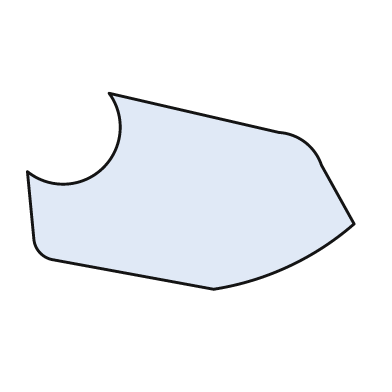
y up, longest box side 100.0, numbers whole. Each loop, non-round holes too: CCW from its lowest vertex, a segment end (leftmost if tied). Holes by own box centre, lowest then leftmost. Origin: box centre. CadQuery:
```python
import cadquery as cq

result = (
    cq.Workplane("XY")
    .moveTo(7.0, -30.0)
    .threePointArc((30.0, -23.0), (50.0, -10.0))
    .lineTo(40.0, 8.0)
    .threePointArc((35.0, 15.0), (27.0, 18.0))
    .lineTo(-25.0, 30.0)
    .threePointArc((-27.0, 7.0), (-50.0, 6.0))
    .lineTo(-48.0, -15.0)
    .threePointArc((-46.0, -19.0), (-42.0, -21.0))
    .close()
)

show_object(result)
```